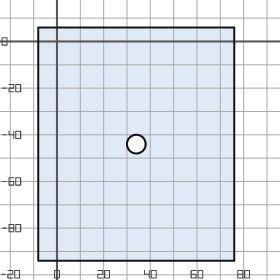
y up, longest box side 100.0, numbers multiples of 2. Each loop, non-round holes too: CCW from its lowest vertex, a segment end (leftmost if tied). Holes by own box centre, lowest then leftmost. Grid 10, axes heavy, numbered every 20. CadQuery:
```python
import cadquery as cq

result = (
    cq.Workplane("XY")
    .moveTo(-8.0, -94.0)
    .lineTo(76.0, -94.0)
    .lineTo(76.0, 6.0)
    .lineTo(-8.0, 6.0)
    .close()
    .moveTo(34.0, -44.0)
    .circle(4.0)
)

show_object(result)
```